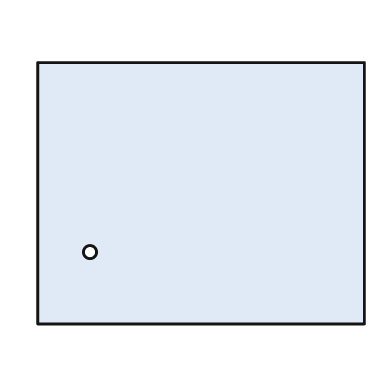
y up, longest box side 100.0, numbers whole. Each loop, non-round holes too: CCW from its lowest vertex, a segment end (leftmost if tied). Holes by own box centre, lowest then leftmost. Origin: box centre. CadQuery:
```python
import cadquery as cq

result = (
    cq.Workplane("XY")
    .moveTo(-50.0, -40.0)
    .lineTo(50.0, -40.0)
    .lineTo(50.0, 40.0)
    .lineTo(-50.0, 40.0)
    .close()
    .moveTo(-34.0, -18.0)
    .circle(2.0)
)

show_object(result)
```